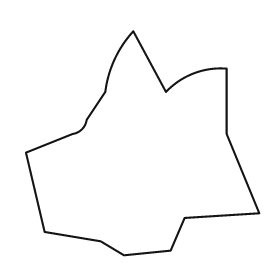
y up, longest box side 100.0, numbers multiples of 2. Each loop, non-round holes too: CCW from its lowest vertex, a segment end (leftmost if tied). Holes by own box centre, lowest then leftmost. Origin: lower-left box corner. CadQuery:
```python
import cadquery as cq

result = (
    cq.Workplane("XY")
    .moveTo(42.0, 0.0)
    .lineTo(62.0, 2.0)
    .lineTo(68.0, 16.0)
    .lineTo(100.0, 18.0)
    .lineTo(86.0, 52.0)
    .lineTo(86.0, 80.0)
    .threePointArc((72.0, 78.0), (60.0, 70.0))
    .lineTo(46.0, 96.0)
    .threePointArc((38.0, 84.0), (34.0, 70.0))
    .lineTo(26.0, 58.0)
    .threePointArc((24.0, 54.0), (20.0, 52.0))
    .lineTo(0.0, 44.0)
    .lineTo(8.0, 10.0)
    .lineTo(32.0, 6.0)
    .close()
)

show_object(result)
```